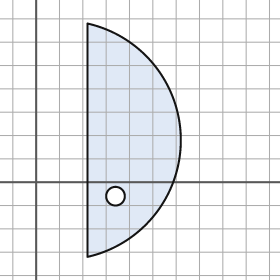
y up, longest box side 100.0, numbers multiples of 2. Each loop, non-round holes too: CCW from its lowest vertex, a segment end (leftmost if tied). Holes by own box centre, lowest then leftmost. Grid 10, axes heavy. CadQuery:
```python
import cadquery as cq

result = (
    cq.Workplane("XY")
    .moveTo(22.0, -32.0)
    .threePointArc((62.0, 18.0), (22.0, 68.0))
    .close()
    .moveTo(34.0, -6.0)
    .circle(4.0)
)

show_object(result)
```